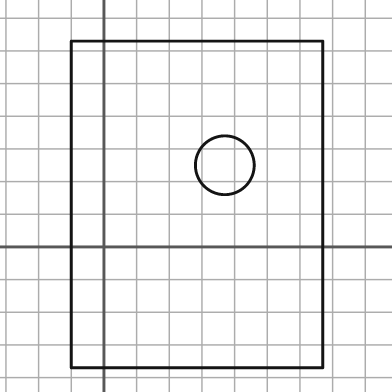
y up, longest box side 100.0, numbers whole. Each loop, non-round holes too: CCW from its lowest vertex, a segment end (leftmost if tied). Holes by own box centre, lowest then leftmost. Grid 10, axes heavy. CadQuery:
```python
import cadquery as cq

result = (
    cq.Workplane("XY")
    .moveTo(-10.0, -37.0)
    .lineTo(67.0, -37.0)
    .lineTo(67.0, 63.0)
    .lineTo(-10.0, 63.0)
    .close()
    .moveTo(37.0, 25.0)
    .circle(9.0)
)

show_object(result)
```